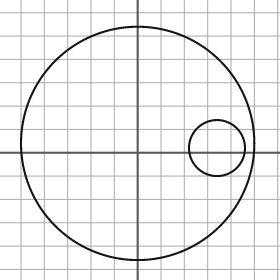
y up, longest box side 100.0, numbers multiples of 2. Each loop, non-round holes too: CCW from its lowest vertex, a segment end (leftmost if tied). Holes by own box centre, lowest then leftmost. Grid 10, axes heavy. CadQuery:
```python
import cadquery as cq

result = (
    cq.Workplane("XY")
    .moveTo(0.0, 4.0)
    .circle(50.0)
    .moveTo(34.0, 2.0)
    .circle(12.0)
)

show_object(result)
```